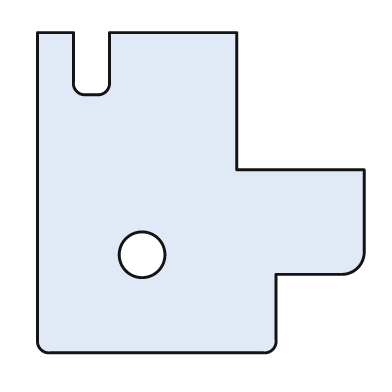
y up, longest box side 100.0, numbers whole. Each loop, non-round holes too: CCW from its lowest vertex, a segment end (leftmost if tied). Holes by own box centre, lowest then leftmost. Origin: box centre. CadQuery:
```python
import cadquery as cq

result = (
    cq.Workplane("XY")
    .moveTo(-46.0, -49.0)
    .lineTo(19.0, -49.0)
    .threePointArc((22.0, -48.0), (23.0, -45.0))
    .lineTo(23.0, -25.0)
    .lineTo(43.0, -25.0)
    .threePointArc((48.0, -23.0), (50.0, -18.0))
    .lineTo(50.0, 7.0)
    .lineTo(11.0, 7.0)
    .lineTo(11.0, 49.0)
    .lineTo(-28.0, 49.0)
    .lineTo(-28.0, 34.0)
    .threePointArc((-29.0, 31.0), (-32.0, 30.0))
    .lineTo(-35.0, 30.0)
    .threePointArc((-38.0, 31.0), (-39.0, 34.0))
    .lineTo(-39.0, 49.0)
    .lineTo(-50.0, 49.0)
    .lineTo(-50.0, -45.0)
    .threePointArc((-49.0, -48.0), (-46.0, -49.0))
    .close()
    .moveTo(-18.0, -19.0)
    .circle(7.0)
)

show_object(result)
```